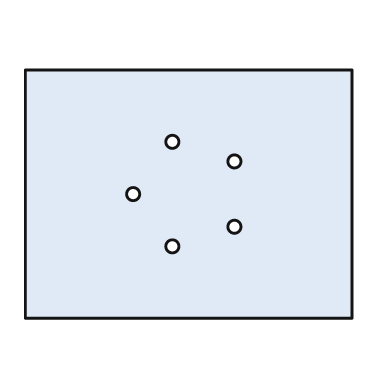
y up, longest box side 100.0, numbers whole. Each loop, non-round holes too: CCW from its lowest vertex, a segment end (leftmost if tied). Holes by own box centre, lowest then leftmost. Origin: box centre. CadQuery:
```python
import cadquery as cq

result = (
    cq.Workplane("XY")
    .moveTo(-50.0, -38.0)
    .lineTo(50.0, -38.0)
    .lineTo(50.0, 38.0)
    .lineTo(-50.0, 38.0)
    .close()
    .moveTo(-5.0, -16.0)
    .circle(2.0)
    .moveTo(14.0, -10.0)
    .circle(2.0)
    .moveTo(-17.0, 0.0)
    .circle(2.0)
    .moveTo(14.0, 10.0)
    .circle(2.0)
    .moveTo(-5.0, 16.0)
    .circle(2.0)
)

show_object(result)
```